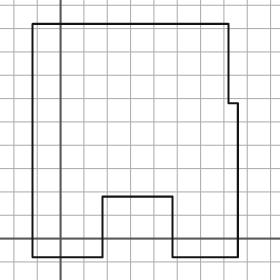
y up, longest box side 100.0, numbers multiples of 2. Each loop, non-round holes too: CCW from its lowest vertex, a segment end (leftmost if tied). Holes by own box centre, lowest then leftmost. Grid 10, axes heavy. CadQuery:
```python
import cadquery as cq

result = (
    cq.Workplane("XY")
    .moveTo(-12.0, -8.0)
    .lineTo(18.0, -8.0)
    .lineTo(18.0, 18.0)
    .lineTo(48.0, 18.0)
    .lineTo(48.0, -8.0)
    .lineTo(76.0, -8.0)
    .lineTo(76.0, 58.0)
    .lineTo(72.0, 58.0)
    .lineTo(72.0, 92.0)
    .lineTo(-12.0, 92.0)
    .close()
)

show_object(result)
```